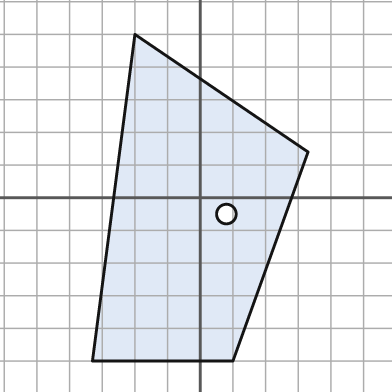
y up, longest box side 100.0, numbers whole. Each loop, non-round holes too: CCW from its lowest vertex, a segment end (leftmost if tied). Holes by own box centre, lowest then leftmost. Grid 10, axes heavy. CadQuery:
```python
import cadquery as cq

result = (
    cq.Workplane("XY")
    .moveTo(-33.0, -50.0)
    .lineTo(10.0, -50.0)
    .lineTo(33.0, 14.0)
    .lineTo(-20.0, 50.0)
    .close()
    .moveTo(8.0, -5.0)
    .circle(3.0)
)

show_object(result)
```